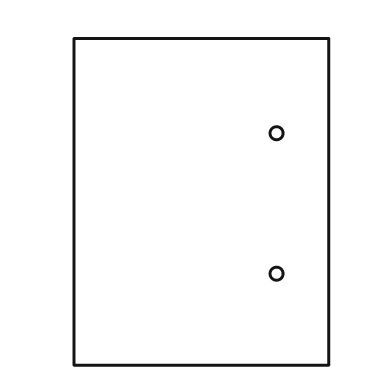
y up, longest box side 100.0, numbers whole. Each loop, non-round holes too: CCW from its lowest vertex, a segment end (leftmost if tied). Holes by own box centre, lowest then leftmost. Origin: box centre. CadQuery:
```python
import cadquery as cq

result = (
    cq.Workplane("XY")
    .moveTo(-39.0, -50.0)
    .lineTo(39.0, -50.0)
    .lineTo(39.0, 50.0)
    .lineTo(-39.0, 50.0)
    .close()
    .moveTo(23.0, -22.0)
    .circle(2.0)
    .moveTo(23.0, 21.0)
    .circle(2.0)
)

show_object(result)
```